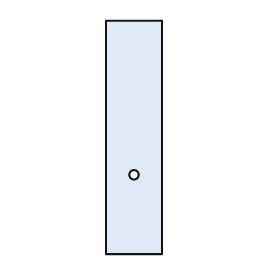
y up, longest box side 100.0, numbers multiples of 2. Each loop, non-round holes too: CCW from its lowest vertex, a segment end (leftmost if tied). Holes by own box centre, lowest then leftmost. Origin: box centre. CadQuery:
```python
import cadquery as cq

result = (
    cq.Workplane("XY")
    .moveTo(-12.0, -50.0)
    .lineTo(12.0, -50.0)
    .lineTo(12.0, 50.0)
    .lineTo(-12.0, 50.0)
    .close()
    .moveTo(0.0, -16.0)
    .circle(2.0)
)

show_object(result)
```